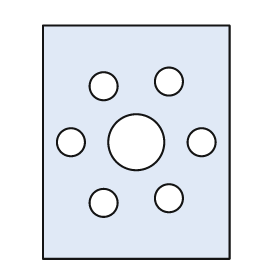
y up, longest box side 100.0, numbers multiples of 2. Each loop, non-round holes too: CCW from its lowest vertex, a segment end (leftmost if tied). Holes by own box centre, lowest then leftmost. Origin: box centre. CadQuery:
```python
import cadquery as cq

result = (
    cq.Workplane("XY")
    .moveTo(-40.0, -50.0)
    .lineTo(40.0, -50.0)
    .lineTo(40.0, 50.0)
    .lineTo(-40.0, 50.0)
    .close()
    .moveTo(-14.0, -26.0)
    .circle(6.0)
    .moveTo(14.0, -24.0)
    .circle(6.0)
    .moveTo(-28.0, 0.0)
    .circle(6.0)
    .moveTo(0.0, 0.0)
    .circle(12.0)
    .moveTo(28.0, 0.0)
    .circle(6.0)
    .moveTo(-14.0, 24.0)
    .circle(6.0)
    .moveTo(14.0, 26.0)
    .circle(6.0)
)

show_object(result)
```